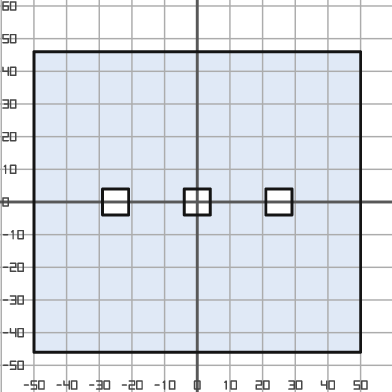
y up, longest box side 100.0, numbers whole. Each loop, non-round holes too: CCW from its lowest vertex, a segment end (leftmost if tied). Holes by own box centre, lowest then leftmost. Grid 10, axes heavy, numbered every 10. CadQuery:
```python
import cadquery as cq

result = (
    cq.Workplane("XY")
    .moveTo(-50.0, -46.0)
    .lineTo(50.0, -46.0)
    .lineTo(50.0, 46.0)
    .lineTo(-50.0, 46.0)
    .close()
    .moveTo(-29.0, -4.0)
    .lineTo(-21.0, -4.0)
    .lineTo(-21.0, 4.0)
    .lineTo(-29.0, 4.0)
    .close()
    .moveTo(-4.0, -4.0)
    .lineTo(4.0, -4.0)
    .lineTo(4.0, 4.0)
    .lineTo(-4.0, 4.0)
    .close()
    .moveTo(21.0, -4.0)
    .lineTo(29.0, -4.0)
    .lineTo(29.0, 4.0)
    .lineTo(21.0, 4.0)
    .close()
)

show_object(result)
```